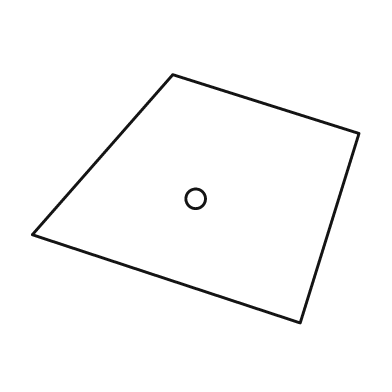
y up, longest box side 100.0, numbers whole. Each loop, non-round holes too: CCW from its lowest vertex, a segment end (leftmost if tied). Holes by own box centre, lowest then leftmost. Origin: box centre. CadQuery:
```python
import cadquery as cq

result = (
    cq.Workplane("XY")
    .moveTo(32.0, -38.0)
    .lineTo(50.0, 20.0)
    .lineTo(-7.0, 38.0)
    .lineTo(-50.0, -11.0)
    .close()
    .moveTo(0.0, 0.0)
    .circle(3.0)
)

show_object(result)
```